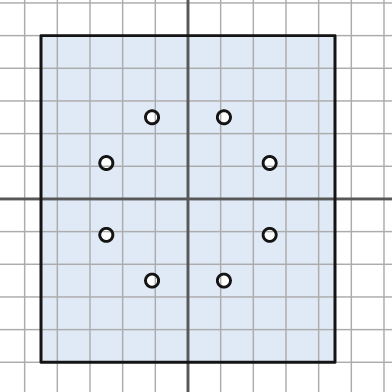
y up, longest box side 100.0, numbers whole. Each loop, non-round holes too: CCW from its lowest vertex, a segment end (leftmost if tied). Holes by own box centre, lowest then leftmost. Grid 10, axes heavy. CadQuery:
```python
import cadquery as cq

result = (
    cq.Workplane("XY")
    .moveTo(-45.0, -50.0)
    .lineTo(45.0, -50.0)
    .lineTo(45.0, 50.0)
    .lineTo(-45.0, 50.0)
    .close()
    .moveTo(-11.0, -25.0)
    .circle(2.0)
    .moveTo(11.0, -25.0)
    .circle(2.0)
    .moveTo(-25.0, -11.0)
    .circle(2.0)
    .moveTo(25.0, -11.0)
    .circle(2.0)
    .moveTo(-25.0, 11.0)
    .circle(2.0)
    .moveTo(25.0, 11.0)
    .circle(2.0)
    .moveTo(-11.0, 25.0)
    .circle(2.0)
    .moveTo(11.0, 25.0)
    .circle(2.0)
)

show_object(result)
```